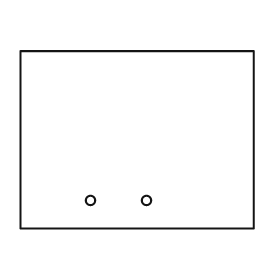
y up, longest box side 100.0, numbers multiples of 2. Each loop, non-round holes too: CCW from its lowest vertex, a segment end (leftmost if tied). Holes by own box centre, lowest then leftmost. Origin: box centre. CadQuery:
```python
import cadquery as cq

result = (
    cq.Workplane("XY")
    .moveTo(-50.0, -38.0)
    .lineTo(50.0, -38.0)
    .lineTo(50.0, 38.0)
    .lineTo(-50.0, 38.0)
    .close()
    .moveTo(-20.0, -26.0)
    .circle(2.0)
    .moveTo(4.0, -26.0)
    .circle(2.0)
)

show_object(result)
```